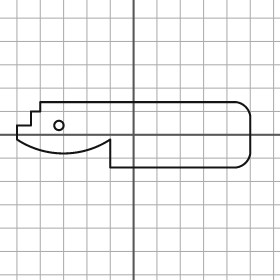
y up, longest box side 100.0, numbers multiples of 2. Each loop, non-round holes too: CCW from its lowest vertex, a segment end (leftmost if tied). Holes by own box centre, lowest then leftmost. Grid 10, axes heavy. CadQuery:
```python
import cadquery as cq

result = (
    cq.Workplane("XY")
    .moveTo(-10.0, -14.0)
    .lineTo(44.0, -14.0)
    .threePointArc((48.0, -12.0), (50.0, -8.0))
    .lineTo(50.0, 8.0)
    .threePointArc((48.0, 12.0), (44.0, 14.0))
    .lineTo(-40.0, 14.0)
    .lineTo(-40.0, 10.0)
    .lineTo(-44.0, 10.0)
    .lineTo(-44.0, 4.0)
    .lineTo(-50.0, 4.0)
    .lineTo(-50.0, -2.0)
    .threePointArc((-30.0, -8.0), (-10.0, -2.0))
    .close()
    .moveTo(-32.0, 4.0)
    .circle(2.0)
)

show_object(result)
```